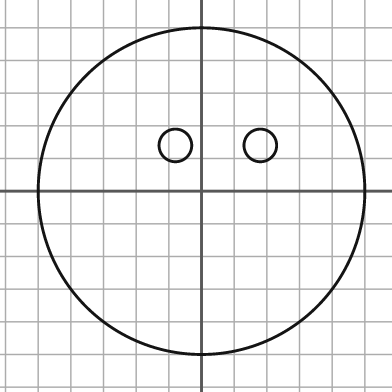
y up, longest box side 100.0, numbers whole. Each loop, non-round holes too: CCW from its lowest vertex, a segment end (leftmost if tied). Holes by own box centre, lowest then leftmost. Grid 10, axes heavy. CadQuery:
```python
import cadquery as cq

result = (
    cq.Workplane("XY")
    .moveTo(0.0, 0.0)
    .circle(50.0)
    .moveTo(-8.0, 14.0)
    .circle(5.0)
    .moveTo(18.0, 14.0)
    .circle(5.0)
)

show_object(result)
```